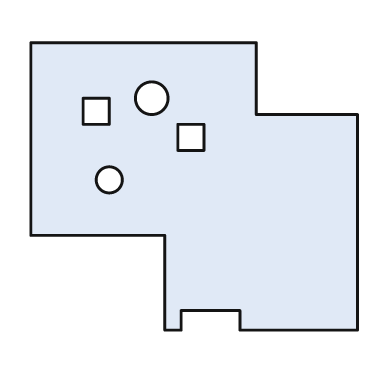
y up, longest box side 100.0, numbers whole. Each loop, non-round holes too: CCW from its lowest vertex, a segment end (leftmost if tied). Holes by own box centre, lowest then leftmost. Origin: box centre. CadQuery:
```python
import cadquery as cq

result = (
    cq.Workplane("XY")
    .moveTo(-9.0, -44.0)
    .lineTo(-4.0, -44.0)
    .lineTo(-4.0, -38.0)
    .lineTo(14.0, -38.0)
    .lineTo(14.0, -44.0)
    .lineTo(50.0, -44.0)
    .lineTo(50.0, 22.0)
    .lineTo(19.0, 22.0)
    .lineTo(19.0, 44.0)
    .lineTo(-50.0, 44.0)
    .lineTo(-50.0, -15.0)
    .lineTo(-9.0, -15.0)
    .close()
    .moveTo(-26.0, 2.0)
    .circle(4.0)
    .moveTo(-5.0, 11.0)
    .lineTo(3.0, 11.0)
    .lineTo(3.0, 19.0)
    .lineTo(-5.0, 19.0)
    .close()
    .moveTo(-34.0, 19.0)
    .lineTo(-26.0, 19.0)
    .lineTo(-26.0, 27.0)
    .lineTo(-34.0, 27.0)
    .close()
    .moveTo(-13.0, 27.0)
    .circle(5.0)
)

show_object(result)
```